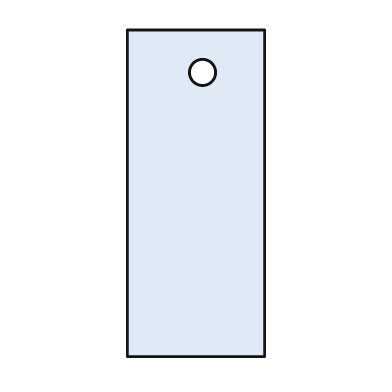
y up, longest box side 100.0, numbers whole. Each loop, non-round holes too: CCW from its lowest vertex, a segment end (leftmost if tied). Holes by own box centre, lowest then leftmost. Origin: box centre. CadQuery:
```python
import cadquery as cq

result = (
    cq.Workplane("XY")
    .moveTo(-21.0, -50.0)
    .lineTo(21.0, -50.0)
    .lineTo(21.0, 50.0)
    .lineTo(-21.0, 50.0)
    .close()
    .moveTo(2.0, 37.0)
    .circle(4.0)
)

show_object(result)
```